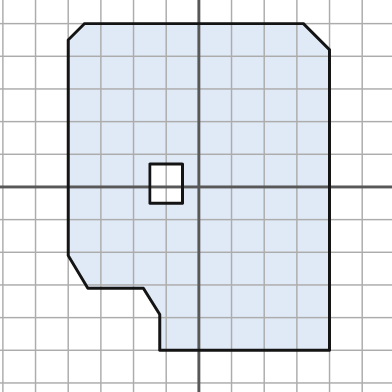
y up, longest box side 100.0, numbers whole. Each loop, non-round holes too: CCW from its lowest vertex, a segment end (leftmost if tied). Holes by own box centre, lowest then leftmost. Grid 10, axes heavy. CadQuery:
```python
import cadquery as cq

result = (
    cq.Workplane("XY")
    .moveTo(-12.0, -50.0)
    .lineTo(40.0, -50.0)
    .lineTo(40.0, 42.0)
    .lineTo(32.0, 50.0)
    .lineTo(-35.0, 50.0)
    .lineTo(-40.0, 45.0)
    .lineTo(-40.0, -21.0)
    .lineTo(-34.0, -31.0)
    .lineTo(-17.0, -31.0)
    .lineTo(-12.0, -39.0)
    .close()
    .moveTo(-15.0, -5.0)
    .lineTo(-5.0, -5.0)
    .lineTo(-5.0, 7.0)
    .lineTo(-15.0, 7.0)
    .close()
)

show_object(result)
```